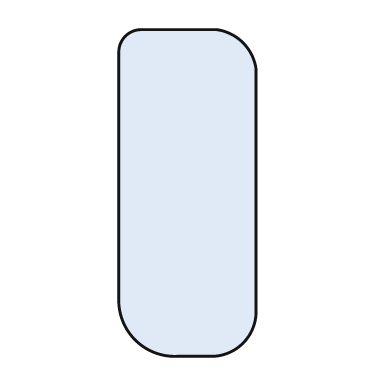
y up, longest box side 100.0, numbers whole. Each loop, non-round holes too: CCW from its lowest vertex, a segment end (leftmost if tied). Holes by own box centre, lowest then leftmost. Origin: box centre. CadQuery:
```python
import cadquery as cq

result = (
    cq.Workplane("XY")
    .moveTo(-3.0, -50.0)
    .lineTo(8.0, -50.0)
    .threePointArc((17.0, -46.0), (21.0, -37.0))
    .lineTo(21.0, 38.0)
    .threePointArc((17.0, 46.0), (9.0, 50.0))
    .lineTo(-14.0, 50.0)
    .threePointArc((-19.0, 48.0), (-21.0, 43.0))
    .lineTo(-21.0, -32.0)
    .threePointArc((-16.0, -45.0), (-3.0, -50.0))
    .close()
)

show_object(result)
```